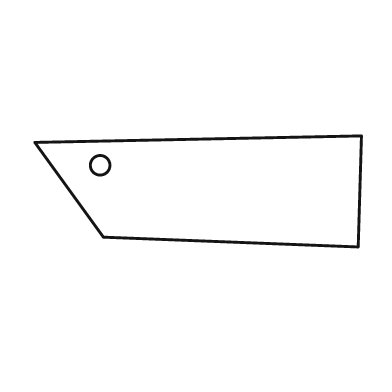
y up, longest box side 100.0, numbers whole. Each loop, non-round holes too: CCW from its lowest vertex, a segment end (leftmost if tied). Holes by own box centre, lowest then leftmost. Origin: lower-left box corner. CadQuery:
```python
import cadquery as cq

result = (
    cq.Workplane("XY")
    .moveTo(99.0, 0.0)
    .lineTo(100.0, 34.0)
    .lineTo(0.0, 32.0)
    .lineTo(21.0, 3.0)
    .close()
    .moveTo(20.0, 25.0)
    .circle(3.0)
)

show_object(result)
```